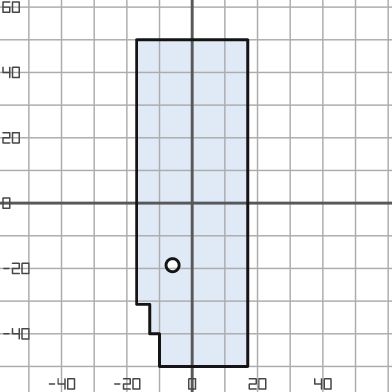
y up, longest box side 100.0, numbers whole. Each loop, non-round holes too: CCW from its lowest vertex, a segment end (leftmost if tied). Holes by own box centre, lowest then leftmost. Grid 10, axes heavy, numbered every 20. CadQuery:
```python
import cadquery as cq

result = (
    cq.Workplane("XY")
    .moveTo(-10.0, -50.0)
    .lineTo(17.0, -50.0)
    .lineTo(17.0, 50.0)
    .lineTo(-17.0, 50.0)
    .lineTo(-17.0, -31.0)
    .lineTo(-13.0, -31.0)
    .lineTo(-13.0, -40.0)
    .lineTo(-10.0, -40.0)
    .close()
    .moveTo(-6.0, -19.0)
    .circle(2.0)
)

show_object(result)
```